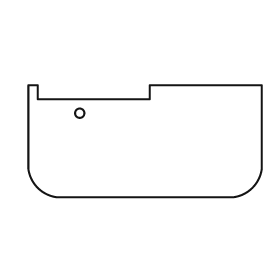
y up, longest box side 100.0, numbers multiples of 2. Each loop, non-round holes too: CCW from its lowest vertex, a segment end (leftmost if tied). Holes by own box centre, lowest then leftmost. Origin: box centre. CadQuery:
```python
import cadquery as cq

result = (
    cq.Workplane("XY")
    .moveTo(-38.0, -24.0)
    .lineTo(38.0, -24.0)
    .threePointArc((46.0, -20.0), (50.0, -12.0))
    .lineTo(50.0, 24.0)
    .lineTo(2.0, 24.0)
    .lineTo(2.0, 18.0)
    .lineTo(-46.0, 18.0)
    .lineTo(-46.0, 24.0)
    .lineTo(-50.0, 24.0)
    .lineTo(-50.0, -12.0)
    .threePointArc((-46.0, -20.0), (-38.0, -24.0))
    .close()
    .moveTo(-28.0, 12.0)
    .circle(2.0)
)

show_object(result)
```